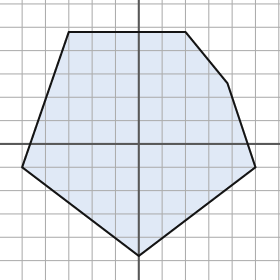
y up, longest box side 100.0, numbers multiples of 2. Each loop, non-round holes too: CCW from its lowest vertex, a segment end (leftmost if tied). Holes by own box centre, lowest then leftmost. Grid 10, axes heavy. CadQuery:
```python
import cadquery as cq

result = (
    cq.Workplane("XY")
    .moveTo(0.0, -48.0)
    .lineTo(50.0, -10.0)
    .lineTo(38.0, 26.0)
    .lineTo(20.0, 48.0)
    .lineTo(-30.0, 48.0)
    .lineTo(-50.0, -10.0)
    .close()
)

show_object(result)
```